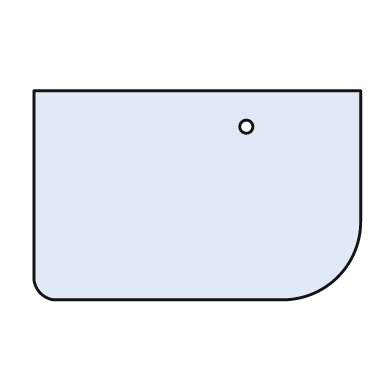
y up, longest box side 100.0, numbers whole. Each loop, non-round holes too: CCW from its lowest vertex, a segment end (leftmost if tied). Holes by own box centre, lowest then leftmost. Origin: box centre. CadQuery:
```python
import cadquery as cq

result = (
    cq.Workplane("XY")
    .moveTo(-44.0, -32.0)
    .lineTo(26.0, -32.0)
    .threePointArc((43.0, -25.0), (50.0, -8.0))
    .lineTo(50.0, 32.0)
    .lineTo(-50.0, 32.0)
    .lineTo(-50.0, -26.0)
    .threePointArc((-48.0, -30.0), (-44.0, -32.0))
    .close()
    .moveTo(15.0, 21.0)
    .circle(2.0)
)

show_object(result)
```